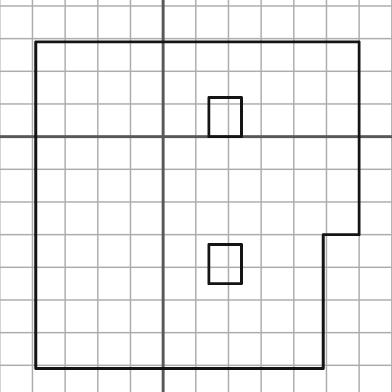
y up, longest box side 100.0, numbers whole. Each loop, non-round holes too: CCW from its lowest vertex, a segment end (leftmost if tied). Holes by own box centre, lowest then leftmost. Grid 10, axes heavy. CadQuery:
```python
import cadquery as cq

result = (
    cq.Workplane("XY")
    .moveTo(-39.0, -71.0)
    .lineTo(49.0, -71.0)
    .lineTo(49.0, -30.0)
    .lineTo(60.0, -30.0)
    .lineTo(60.0, 29.0)
    .lineTo(-39.0, 29.0)
    .close()
    .moveTo(14.0, -45.0)
    .lineTo(24.0, -45.0)
    .lineTo(24.0, -33.0)
    .lineTo(14.0, -33.0)
    .close()
    .moveTo(14.0, 0.0)
    .lineTo(24.0, 0.0)
    .lineTo(24.0, 12.0)
    .lineTo(14.0, 12.0)
    .close()
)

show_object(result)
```